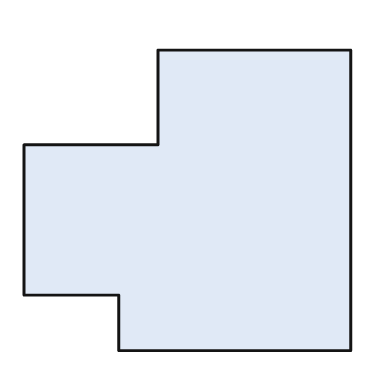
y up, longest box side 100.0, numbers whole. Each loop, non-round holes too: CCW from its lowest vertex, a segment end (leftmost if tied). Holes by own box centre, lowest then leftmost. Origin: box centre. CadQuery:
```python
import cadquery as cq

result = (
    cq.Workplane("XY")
    .moveTo(-21.0, -46.0)
    .lineTo(50.0, -46.0)
    .lineTo(50.0, 46.0)
    .lineTo(-9.0, 46.0)
    .lineTo(-9.0, 17.0)
    .lineTo(-50.0, 17.0)
    .lineTo(-50.0, -29.0)
    .lineTo(-21.0, -29.0)
    .close()
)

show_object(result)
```